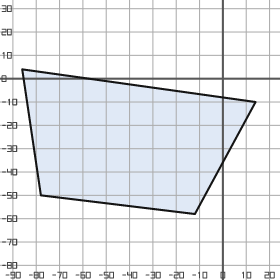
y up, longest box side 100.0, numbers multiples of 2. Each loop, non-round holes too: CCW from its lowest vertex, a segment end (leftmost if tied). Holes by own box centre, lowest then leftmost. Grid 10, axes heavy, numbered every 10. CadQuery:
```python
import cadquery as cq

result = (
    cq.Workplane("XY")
    .moveTo(-12.0, -58.0)
    .lineTo(14.0, -10.0)
    .lineTo(-86.0, 4.0)
    .lineTo(-78.0, -50.0)
    .close()
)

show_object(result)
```